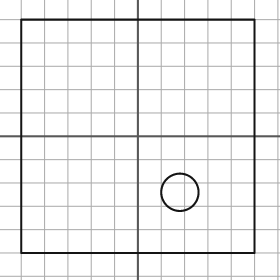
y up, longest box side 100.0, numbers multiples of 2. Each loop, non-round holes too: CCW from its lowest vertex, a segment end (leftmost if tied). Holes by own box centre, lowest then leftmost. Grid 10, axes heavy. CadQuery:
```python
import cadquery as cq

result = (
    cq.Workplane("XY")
    .moveTo(-50.0, -50.0)
    .lineTo(50.0, -50.0)
    .lineTo(50.0, 50.0)
    .lineTo(-50.0, 50.0)
    .close()
    .moveTo(18.0, -24.0)
    .circle(8.0)
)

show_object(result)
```